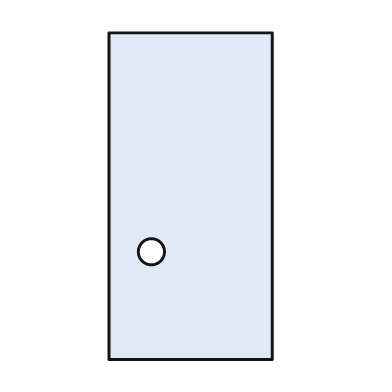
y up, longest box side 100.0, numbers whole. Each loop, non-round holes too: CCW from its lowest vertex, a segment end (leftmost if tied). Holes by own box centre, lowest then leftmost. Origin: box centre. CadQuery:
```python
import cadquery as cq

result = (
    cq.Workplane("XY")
    .moveTo(-25.0, -50.0)
    .lineTo(25.0, -50.0)
    .lineTo(25.0, 50.0)
    .lineTo(-25.0, 50.0)
    .close()
    .moveTo(-12.0, -17.0)
    .circle(4.0)
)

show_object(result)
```